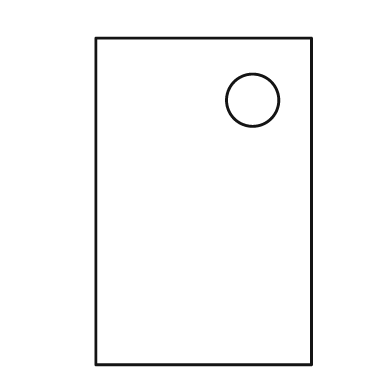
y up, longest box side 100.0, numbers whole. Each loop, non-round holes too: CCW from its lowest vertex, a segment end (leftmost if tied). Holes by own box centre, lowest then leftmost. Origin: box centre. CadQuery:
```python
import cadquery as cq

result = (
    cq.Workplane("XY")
    .moveTo(-33.0, -50.0)
    .lineTo(33.0, -50.0)
    .lineTo(33.0, 50.0)
    .lineTo(-33.0, 50.0)
    .close()
    .moveTo(15.0, 31.0)
    .circle(8.0)
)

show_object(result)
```